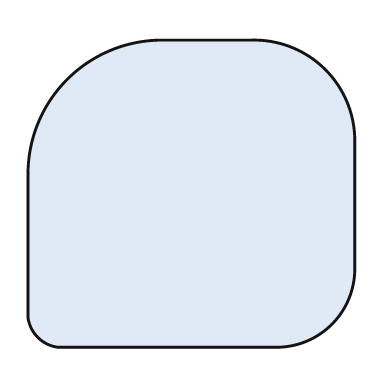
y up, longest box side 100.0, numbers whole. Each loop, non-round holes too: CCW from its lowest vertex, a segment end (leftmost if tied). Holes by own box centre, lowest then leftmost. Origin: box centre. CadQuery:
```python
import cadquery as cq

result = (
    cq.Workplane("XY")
    .moveTo(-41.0, -47.0)
    .lineTo(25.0, -47.0)
    .threePointArc((43.0, -40.0), (50.0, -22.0))
    .lineTo(50.0, 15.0)
    .threePointArc((41.0, 38.0), (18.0, 47.0))
    .lineTo(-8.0, 47.0)
    .threePointArc((-38.0, 35.0), (-50.0, 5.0))
    .lineTo(-50.0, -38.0)
    .threePointArc((-47.0, -44.0), (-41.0, -47.0))
    .close()
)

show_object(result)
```